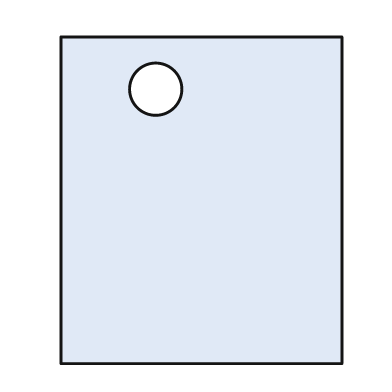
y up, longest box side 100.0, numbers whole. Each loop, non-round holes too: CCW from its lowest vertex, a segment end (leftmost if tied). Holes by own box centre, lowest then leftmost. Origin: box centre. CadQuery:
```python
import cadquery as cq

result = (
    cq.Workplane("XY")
    .moveTo(-43.0, -50.0)
    .lineTo(43.0, -50.0)
    .lineTo(43.0, 50.0)
    .lineTo(-43.0, 50.0)
    .close()
    .moveTo(-14.0, 34.0)
    .circle(8.0)
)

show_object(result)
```